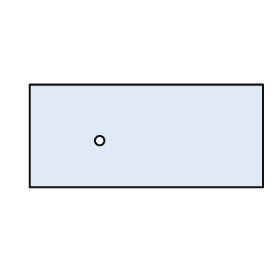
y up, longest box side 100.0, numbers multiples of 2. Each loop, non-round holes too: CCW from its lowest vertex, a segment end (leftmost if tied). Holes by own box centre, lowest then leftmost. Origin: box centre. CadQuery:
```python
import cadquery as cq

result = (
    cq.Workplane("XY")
    .moveTo(-50.0, -22.0)
    .lineTo(50.0, -22.0)
    .lineTo(50.0, 22.0)
    .lineTo(-50.0, 22.0)
    .close()
    .moveTo(-20.0, -2.0)
    .circle(2.0)
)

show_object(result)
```